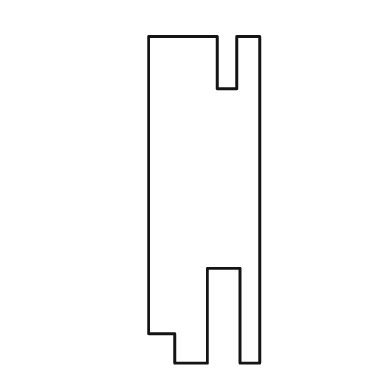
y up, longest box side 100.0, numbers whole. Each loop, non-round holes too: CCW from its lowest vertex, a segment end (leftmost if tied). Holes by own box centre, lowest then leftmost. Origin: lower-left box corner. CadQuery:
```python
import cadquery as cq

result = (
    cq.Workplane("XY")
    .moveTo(8.0, 0.0)
    .lineTo(18.0, 0.0)
    .lineTo(18.0, 29.0)
    .lineTo(28.0, 29.0)
    .lineTo(28.0, 0.0)
    .lineTo(34.0, 0.0)
    .lineTo(34.0, 100.0)
    .lineTo(27.0, 100.0)
    .lineTo(27.0, 84.0)
    .lineTo(21.0, 84.0)
    .lineTo(21.0, 100.0)
    .lineTo(0.0, 100.0)
    .lineTo(0.0, 9.0)
    .lineTo(8.0, 9.0)
    .close()
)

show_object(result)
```